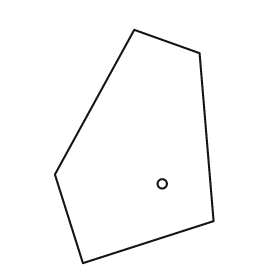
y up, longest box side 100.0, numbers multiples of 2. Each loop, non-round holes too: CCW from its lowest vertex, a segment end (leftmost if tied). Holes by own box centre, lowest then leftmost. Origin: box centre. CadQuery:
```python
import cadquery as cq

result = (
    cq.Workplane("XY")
    .moveTo(-22.0, -50.0)
    .lineTo(34.0, -32.0)
    .lineTo(28.0, 40.0)
    .lineTo(0.0, 50.0)
    .lineTo(-34.0, -12.0)
    .close()
    .moveTo(12.0, -16.0)
    .circle(2.0)
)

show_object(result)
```